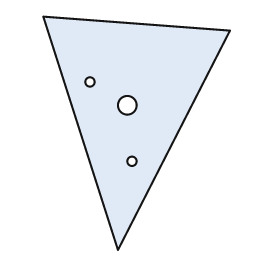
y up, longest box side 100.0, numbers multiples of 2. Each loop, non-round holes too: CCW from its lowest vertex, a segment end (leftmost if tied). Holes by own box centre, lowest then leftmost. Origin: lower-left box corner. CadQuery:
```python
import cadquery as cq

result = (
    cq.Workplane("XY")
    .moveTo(32.0, 0.0)
    .lineTo(80.0, 94.0)
    .lineTo(0.0, 100.0)
    .close()
    .moveTo(38.0, 38.0)
    .circle(2.0)
    .moveTo(36.0, 62.0)
    .circle(4.0)
    .moveTo(20.0, 72.0)
    .circle(2.0)
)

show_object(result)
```